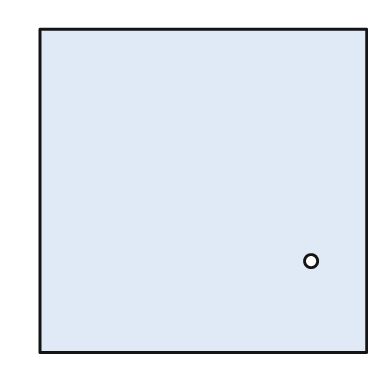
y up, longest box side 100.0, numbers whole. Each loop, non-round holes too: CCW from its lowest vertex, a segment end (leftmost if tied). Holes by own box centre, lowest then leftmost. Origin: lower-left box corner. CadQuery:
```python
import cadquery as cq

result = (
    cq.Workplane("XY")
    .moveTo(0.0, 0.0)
    .lineTo(100.0, 0.0)
    .lineTo(100.0, 99.0)
    .lineTo(0.0, 99.0)
    .close()
    .moveTo(83.0, 28.0)
    .circle(2.0)
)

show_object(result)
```